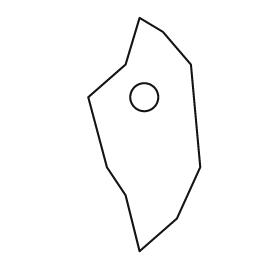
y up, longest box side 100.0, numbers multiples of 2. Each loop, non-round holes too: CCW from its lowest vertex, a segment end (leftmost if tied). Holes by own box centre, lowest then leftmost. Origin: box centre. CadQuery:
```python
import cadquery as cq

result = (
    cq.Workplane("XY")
    .moveTo(-2.0, -50.0)
    .lineTo(14.0, -36.0)
    .lineTo(24.0, -14.0)
    .lineTo(20.0, 30.0)
    .lineTo(8.0, 44.0)
    .lineTo(-2.0, 50.0)
    .lineTo(-8.0, 30.0)
    .lineTo(-24.0, 16.0)
    .lineTo(-16.0, -14.0)
    .lineTo(-8.0, -26.0)
    .close()
    .moveTo(0.0, 16.0)
    .circle(6.0)
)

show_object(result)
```